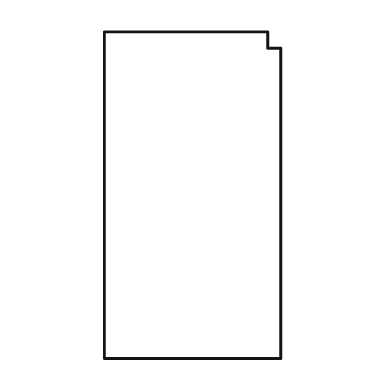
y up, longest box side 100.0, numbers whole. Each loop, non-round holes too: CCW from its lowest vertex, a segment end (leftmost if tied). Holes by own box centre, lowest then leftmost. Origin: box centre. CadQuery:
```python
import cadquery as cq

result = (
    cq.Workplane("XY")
    .moveTo(-27.0, -50.0)
    .lineTo(27.0, -50.0)
    .lineTo(27.0, 45.0)
    .lineTo(23.0, 45.0)
    .lineTo(23.0, 50.0)
    .lineTo(-27.0, 50.0)
    .close()
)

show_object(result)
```